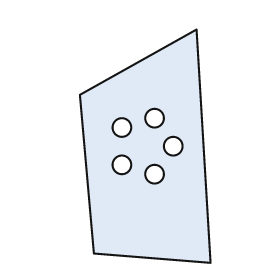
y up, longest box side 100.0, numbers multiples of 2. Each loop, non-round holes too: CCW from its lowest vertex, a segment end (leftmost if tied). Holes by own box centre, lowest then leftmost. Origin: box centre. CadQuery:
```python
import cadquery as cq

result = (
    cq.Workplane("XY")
    .moveTo(28.0, -50.0)
    .lineTo(22.0, 50.0)
    .lineTo(-28.0, 22.0)
    .lineTo(-22.0, -46.0)
    .close()
    .moveTo(4.0, -12.0)
    .circle(4.0)
    .moveTo(-10.0, -8.0)
    .circle(4.0)
    .moveTo(12.0, 0.0)
    .circle(4.0)
    .moveTo(-10.0, 8.0)
    .circle(4.0)
    .moveTo(4.0, 12.0)
    .circle(4.0)
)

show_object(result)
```